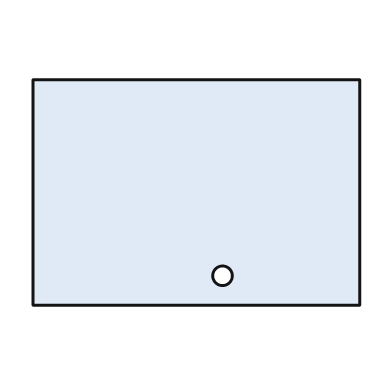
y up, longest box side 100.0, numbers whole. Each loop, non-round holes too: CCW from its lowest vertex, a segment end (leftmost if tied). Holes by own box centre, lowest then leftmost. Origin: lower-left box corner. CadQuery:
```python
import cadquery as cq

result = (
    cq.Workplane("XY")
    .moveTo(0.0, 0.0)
    .lineTo(100.0, 0.0)
    .lineTo(100.0, 69.0)
    .lineTo(0.0, 69.0)
    .close()
    .moveTo(58.0, 9.0)
    .circle(3.0)
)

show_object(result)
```